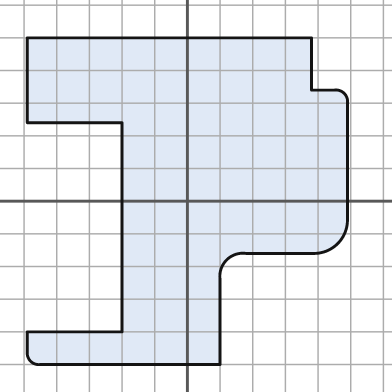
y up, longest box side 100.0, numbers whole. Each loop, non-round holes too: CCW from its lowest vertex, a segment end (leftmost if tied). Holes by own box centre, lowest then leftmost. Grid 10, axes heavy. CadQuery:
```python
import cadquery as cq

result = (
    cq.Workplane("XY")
    .moveTo(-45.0, -50.0)
    .lineTo(10.0, -50.0)
    .lineTo(10.0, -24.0)
    .threePointArc((12.0, -18.0), (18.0, -16.0))
    .lineTo(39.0, -16.0)
    .threePointArc((46.0, -13.0), (49.0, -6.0))
    .lineTo(49.0, 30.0)
    .threePointArc((48.0, 33.0), (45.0, 34.0))
    .lineTo(38.0, 34.0)
    .lineTo(38.0, 50.0)
    .lineTo(-49.0, 50.0)
    .lineTo(-49.0, 24.0)
    .lineTo(-20.0, 24.0)
    .lineTo(-20.0, -40.0)
    .lineTo(-49.0, -40.0)
    .lineTo(-49.0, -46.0)
    .threePointArc((-48.0, -49.0), (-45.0, -50.0))
    .close()
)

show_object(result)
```